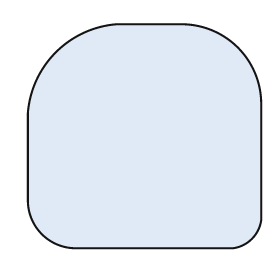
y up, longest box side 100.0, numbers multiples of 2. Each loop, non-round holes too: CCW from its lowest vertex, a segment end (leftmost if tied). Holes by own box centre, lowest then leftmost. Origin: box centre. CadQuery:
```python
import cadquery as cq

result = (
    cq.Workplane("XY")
    .moveTo(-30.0, -48.0)
    .lineTo(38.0, -48.0)
    .threePointArc((46.0, -44.0), (50.0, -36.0))
    .lineTo(50.0, 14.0)
    .threePointArc((40.0, 38.0), (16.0, 48.0))
    .lineTo(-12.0, 48.0)
    .threePointArc((-38.0, 36.0), (-50.0, 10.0))
    .lineTo(-50.0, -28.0)
    .threePointArc((-44.0, -42.0), (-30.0, -48.0))
    .close()
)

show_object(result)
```